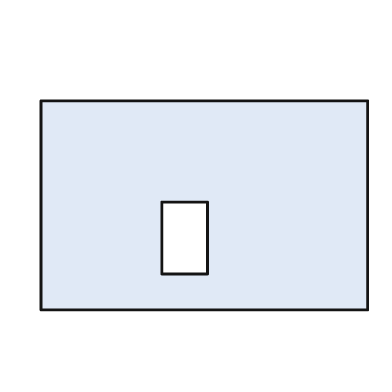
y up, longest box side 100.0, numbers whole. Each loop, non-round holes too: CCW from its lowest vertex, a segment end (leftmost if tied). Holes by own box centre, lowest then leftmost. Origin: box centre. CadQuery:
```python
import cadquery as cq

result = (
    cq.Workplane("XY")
    .moveTo(-50.0, -32.0)
    .lineTo(50.0, -32.0)
    .lineTo(50.0, 32.0)
    .lineTo(-50.0, 32.0)
    .close()
    .moveTo(-13.0, -21.0)
    .lineTo(1.0, -21.0)
    .lineTo(1.0, 1.0)
    .lineTo(-13.0, 1.0)
    .close()
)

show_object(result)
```